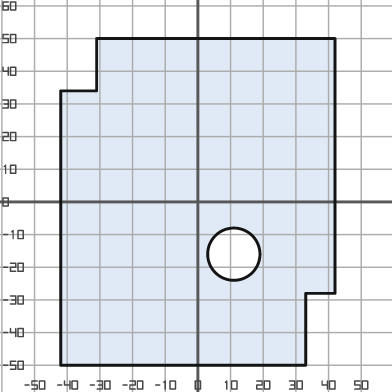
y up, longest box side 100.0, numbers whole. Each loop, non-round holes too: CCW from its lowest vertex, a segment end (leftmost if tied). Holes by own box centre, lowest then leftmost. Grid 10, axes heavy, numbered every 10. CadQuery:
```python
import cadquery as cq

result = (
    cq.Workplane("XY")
    .moveTo(-42.0, -50.0)
    .lineTo(33.0, -50.0)
    .lineTo(33.0, -28.0)
    .lineTo(42.0, -28.0)
    .lineTo(42.0, 50.0)
    .lineTo(-31.0, 50.0)
    .lineTo(-31.0, 34.0)
    .lineTo(-42.0, 34.0)
    .close()
    .moveTo(11.0, -16.0)
    .circle(8.0)
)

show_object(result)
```